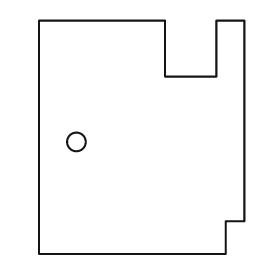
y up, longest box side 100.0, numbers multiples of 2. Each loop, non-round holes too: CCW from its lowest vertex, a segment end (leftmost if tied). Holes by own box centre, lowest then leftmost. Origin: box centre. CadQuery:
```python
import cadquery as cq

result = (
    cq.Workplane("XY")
    .moveTo(-44.0, -50.0)
    .lineTo(36.0, -50.0)
    .lineTo(36.0, -36.0)
    .lineTo(44.0, -36.0)
    .lineTo(44.0, 50.0)
    .lineTo(32.0, 50.0)
    .lineTo(32.0, 26.0)
    .lineTo(10.0, 26.0)
    .lineTo(10.0, 50.0)
    .lineTo(-44.0, 50.0)
    .close()
    .moveTo(-28.0, -2.0)
    .circle(4.0)
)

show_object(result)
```